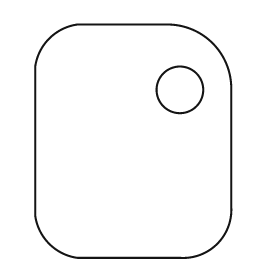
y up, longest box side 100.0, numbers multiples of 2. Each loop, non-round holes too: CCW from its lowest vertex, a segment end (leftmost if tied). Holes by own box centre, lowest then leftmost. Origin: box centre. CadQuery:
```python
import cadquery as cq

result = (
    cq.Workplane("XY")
    .moveTo(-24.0, -50.0)
    .lineTo(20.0, -50.0)
    .threePointArc((36.0, -44.0), (42.0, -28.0))
    .lineTo(42.0, 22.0)
    .threePointArc((34.0, 42.0), (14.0, 50.0))
    .lineTo(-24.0, 50.0)
    .threePointArc((-36.0, 44.0), (-42.0, 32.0))
    .lineTo(-42.0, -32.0)
    .threePointArc((-36.0, -44.0), (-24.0, -50.0))
    .close()
    .moveTo(20.0, 22.0)
    .circle(10.0)
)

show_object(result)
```